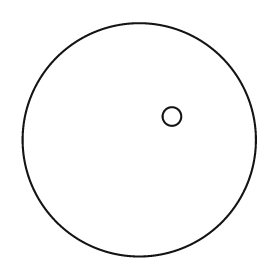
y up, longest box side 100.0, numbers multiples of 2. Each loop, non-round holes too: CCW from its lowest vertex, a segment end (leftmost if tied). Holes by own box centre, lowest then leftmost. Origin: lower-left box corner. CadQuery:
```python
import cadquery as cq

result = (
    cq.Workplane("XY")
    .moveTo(50.0, 50.0)
    .circle(50.0)
    .moveTo(64.0, 60.0)
    .circle(4.0)
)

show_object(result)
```